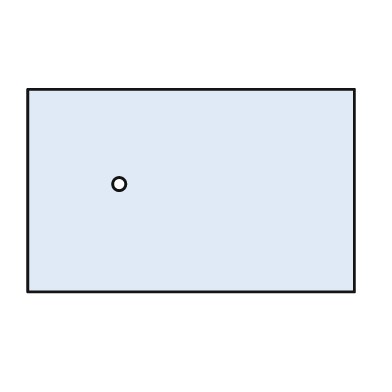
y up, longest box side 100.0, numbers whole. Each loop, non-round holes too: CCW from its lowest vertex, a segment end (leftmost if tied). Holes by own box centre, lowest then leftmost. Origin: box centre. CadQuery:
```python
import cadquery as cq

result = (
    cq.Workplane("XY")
    .moveTo(-50.0, -31.0)
    .lineTo(50.0, -31.0)
    .lineTo(50.0, 31.0)
    .lineTo(-50.0, 31.0)
    .close()
    .moveTo(-22.0, 2.0)
    .circle(2.0)
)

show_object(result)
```